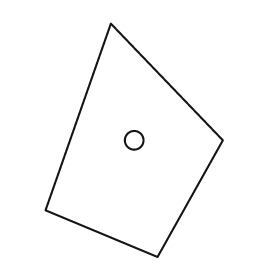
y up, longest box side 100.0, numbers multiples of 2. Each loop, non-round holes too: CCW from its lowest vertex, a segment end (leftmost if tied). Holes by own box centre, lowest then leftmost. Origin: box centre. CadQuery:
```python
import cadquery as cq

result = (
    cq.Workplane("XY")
    .moveTo(10.0, -50.0)
    .lineTo(38.0, 0.0)
    .lineTo(-10.0, 50.0)
    .lineTo(-38.0, -30.0)
    .close()
    .moveTo(0.0, 0.0)
    .circle(4.0)
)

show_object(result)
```